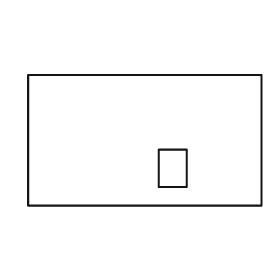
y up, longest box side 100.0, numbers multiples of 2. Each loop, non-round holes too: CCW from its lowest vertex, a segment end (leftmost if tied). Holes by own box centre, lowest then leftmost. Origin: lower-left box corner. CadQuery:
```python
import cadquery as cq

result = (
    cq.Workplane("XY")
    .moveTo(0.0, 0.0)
    .lineTo(100.0, 0.0)
    .lineTo(100.0, 56.0)
    .lineTo(0.0, 56.0)
    .close()
    .moveTo(56.0, 8.0)
    .lineTo(68.0, 8.0)
    .lineTo(68.0, 24.0)
    .lineTo(56.0, 24.0)
    .close()
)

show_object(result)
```